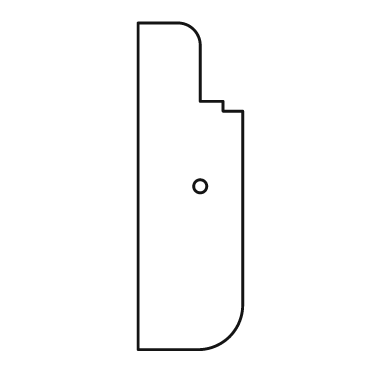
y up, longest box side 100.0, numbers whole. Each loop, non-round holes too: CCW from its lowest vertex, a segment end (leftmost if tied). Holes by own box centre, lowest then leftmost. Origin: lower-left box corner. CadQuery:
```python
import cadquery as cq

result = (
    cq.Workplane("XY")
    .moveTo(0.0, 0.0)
    .lineTo(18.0, 0.0)
    .threePointArc((28.0, 4.0), (32.0, 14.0))
    .lineTo(32.0, 73.0)
    .lineTo(26.0, 73.0)
    .lineTo(26.0, 76.0)
    .lineTo(19.0, 76.0)
    .lineTo(19.0, 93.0)
    .threePointArc((17.0, 98.0), (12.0, 100.0))
    .lineTo(0.0, 100.0)
    .close()
    .moveTo(19.0, 50.0)
    .circle(2.0)
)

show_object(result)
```